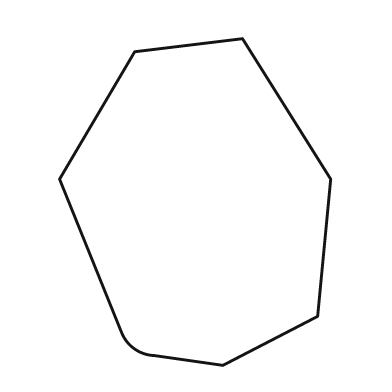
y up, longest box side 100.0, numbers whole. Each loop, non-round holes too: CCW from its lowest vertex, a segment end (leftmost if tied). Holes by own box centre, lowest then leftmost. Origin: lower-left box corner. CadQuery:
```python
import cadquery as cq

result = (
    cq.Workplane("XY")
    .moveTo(50.0, 0.0)
    .lineTo(79.0, 15.0)
    .lineTo(83.0, 57.0)
    .lineTo(56.0, 100.0)
    .lineTo(23.0, 96.0)
    .lineTo(0.0, 57.0)
    .lineTo(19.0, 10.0)
    .threePointArc((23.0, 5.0), (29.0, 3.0))
    .close()
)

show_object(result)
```